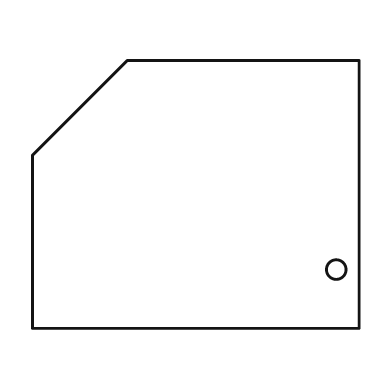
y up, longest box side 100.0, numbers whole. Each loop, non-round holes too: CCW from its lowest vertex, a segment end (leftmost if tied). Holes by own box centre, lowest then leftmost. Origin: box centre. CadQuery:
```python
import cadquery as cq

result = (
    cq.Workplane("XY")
    .moveTo(-50.0, -41.0)
    .lineTo(50.0, -41.0)
    .lineTo(50.0, 41.0)
    .lineTo(-21.0, 41.0)
    .lineTo(-50.0, 12.0)
    .close()
    .moveTo(43.0, -23.0)
    .circle(3.0)
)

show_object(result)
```